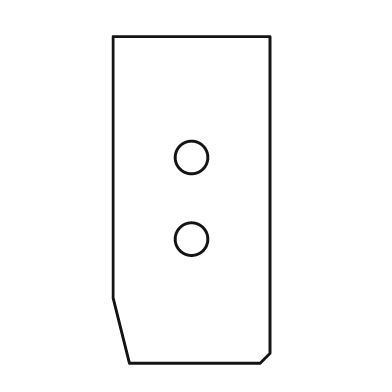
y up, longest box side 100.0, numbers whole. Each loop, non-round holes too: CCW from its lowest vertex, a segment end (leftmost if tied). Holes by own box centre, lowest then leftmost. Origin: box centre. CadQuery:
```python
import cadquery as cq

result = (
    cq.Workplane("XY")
    .moveTo(-19.0, -50.0)
    .lineTo(21.0, -50.0)
    .lineTo(24.0, -47.0)
    .lineTo(24.0, 50.0)
    .lineTo(-24.0, 50.0)
    .lineTo(-24.0, -30.0)
    .close()
    .moveTo(0.0, -12.0)
    .circle(5.0)
    .moveTo(0.0, 13.0)
    .circle(5.0)
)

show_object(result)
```